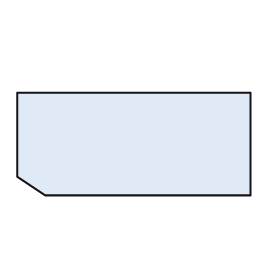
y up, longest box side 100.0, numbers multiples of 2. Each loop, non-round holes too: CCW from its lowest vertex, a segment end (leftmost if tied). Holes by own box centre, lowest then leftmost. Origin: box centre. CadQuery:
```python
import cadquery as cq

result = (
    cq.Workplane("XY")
    .moveTo(-38.0, -22.0)
    .lineTo(50.0, -22.0)
    .lineTo(50.0, 22.0)
    .lineTo(-50.0, 22.0)
    .lineTo(-50.0, -14.0)
    .close()
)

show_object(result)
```